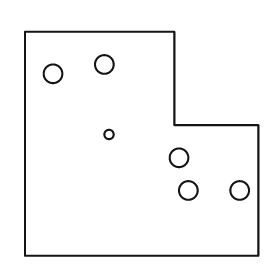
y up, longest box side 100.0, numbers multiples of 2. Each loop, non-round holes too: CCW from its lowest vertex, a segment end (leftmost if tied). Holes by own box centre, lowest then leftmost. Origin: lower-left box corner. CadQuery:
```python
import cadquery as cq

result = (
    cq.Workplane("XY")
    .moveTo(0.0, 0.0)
    .lineTo(100.0, 0.0)
    .lineTo(100.0, 56.0)
    .lineTo(64.0, 56.0)
    .lineTo(64.0, 96.0)
    .lineTo(0.0, 96.0)
    .close()
    .moveTo(70.0, 28.0)
    .circle(4.0)
    .moveTo(92.0, 28.0)
    .circle(4.0)
    .moveTo(66.0, 42.0)
    .circle(4.0)
    .moveTo(36.0, 52.0)
    .circle(2.0)
    .moveTo(12.0, 78.0)
    .circle(4.0)
    .moveTo(34.0, 82.0)
    .circle(4.0)
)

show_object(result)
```